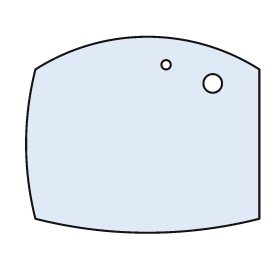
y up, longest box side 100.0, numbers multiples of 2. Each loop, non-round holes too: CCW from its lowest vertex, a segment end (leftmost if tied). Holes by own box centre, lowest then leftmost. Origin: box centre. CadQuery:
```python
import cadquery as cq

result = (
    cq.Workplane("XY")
    .moveTo(-46.0, -36.0)
    .threePointArc((2.0, -42.0), (50.0, -36.0))
    .lineTo(50.0, 28.0)
    .threePointArc((2.0, 42.0), (-46.0, 28.0))
    .threePointArc((-50.0, -4.0), (-46.0, -36.0))
    .close()
    .moveTo(30.0, 22.0)
    .circle(4.0)
    .moveTo(10.0, 30.0)
    .circle(2.0)
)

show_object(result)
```